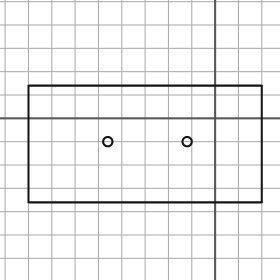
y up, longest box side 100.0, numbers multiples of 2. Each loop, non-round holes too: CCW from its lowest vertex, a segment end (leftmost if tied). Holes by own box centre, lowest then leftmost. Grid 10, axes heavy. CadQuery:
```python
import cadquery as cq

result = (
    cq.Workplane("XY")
    .moveTo(-80.0, -36.0)
    .lineTo(20.0, -36.0)
    .lineTo(20.0, 14.0)
    .lineTo(-80.0, 14.0)
    .close()
    .moveTo(-46.0, -10.0)
    .circle(2.0)
    .moveTo(-12.0, -10.0)
    .circle(2.0)
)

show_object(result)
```